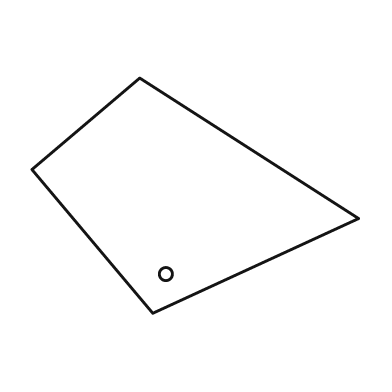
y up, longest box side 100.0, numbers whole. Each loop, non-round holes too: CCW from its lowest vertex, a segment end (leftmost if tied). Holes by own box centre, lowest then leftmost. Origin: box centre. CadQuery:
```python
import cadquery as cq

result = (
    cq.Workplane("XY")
    .moveTo(-13.0, -36.0)
    .lineTo(50.0, -7.0)
    .lineTo(-17.0, 36.0)
    .lineTo(-50.0, 8.0)
    .close()
    .moveTo(-9.0, -24.0)
    .circle(2.0)
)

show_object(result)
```